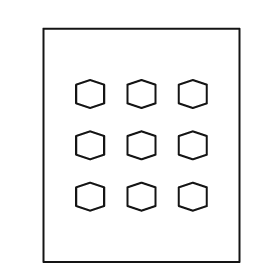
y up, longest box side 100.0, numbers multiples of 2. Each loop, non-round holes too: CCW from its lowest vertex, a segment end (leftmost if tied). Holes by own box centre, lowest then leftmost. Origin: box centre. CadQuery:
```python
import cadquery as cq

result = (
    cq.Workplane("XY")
    .moveTo(-42.0, -50.0)
    .lineTo(42.0, -50.0)
    .lineTo(42.0, 50.0)
    .lineTo(-42.0, 50.0)
    .close()
    .moveTo(-22.0, -28.0)
    .lineTo(-16.0, -26.0)
    .lineTo(-16.0, -18.0)
    .lineTo(-22.0, -16.0)
    .lineTo(-28.0, -18.0)
    .lineTo(-28.0, -26.0)
    .close()
    .moveTo(0.0, -28.0)
    .lineTo(6.0, -26.0)
    .lineTo(6.0, -18.0)
    .lineTo(0.0, -16.0)
    .lineTo(-6.0, -18.0)
    .lineTo(-6.0, -26.0)
    .close()
    .moveTo(22.0, -28.0)
    .lineTo(28.0, -26.0)
    .lineTo(28.0, -18.0)
    .lineTo(22.0, -16.0)
    .lineTo(16.0, -18.0)
    .lineTo(16.0, -26.0)
    .close()
    .moveTo(-22.0, -6.0)
    .lineTo(-16.0, -4.0)
    .lineTo(-16.0, 4.0)
    .lineTo(-22.0, 6.0)
    .lineTo(-28.0, 4.0)
    .lineTo(-28.0, -4.0)
    .close()
    .moveTo(0.0, -6.0)
    .lineTo(6.0, -4.0)
    .lineTo(6.0, 4.0)
    .lineTo(0.0, 6.0)
    .lineTo(-6.0, 4.0)
    .lineTo(-6.0, -4.0)
    .close()
    .moveTo(22.0, -6.0)
    .lineTo(28.0, -4.0)
    .lineTo(28.0, 4.0)
    .lineTo(22.0, 6.0)
    .lineTo(16.0, 4.0)
    .lineTo(16.0, -4.0)
    .close()
    .moveTo(-22.0, 16.0)
    .lineTo(-16.0, 18.0)
    .lineTo(-16.0, 26.0)
    .lineTo(-22.0, 28.0)
    .lineTo(-28.0, 26.0)
    .lineTo(-28.0, 18.0)
    .close()
    .moveTo(0.0, 16.0)
    .lineTo(6.0, 18.0)
    .lineTo(6.0, 26.0)
    .lineTo(0.0, 28.0)
    .lineTo(-6.0, 26.0)
    .lineTo(-6.0, 18.0)
    .close()
    .moveTo(22.0, 16.0)
    .lineTo(28.0, 18.0)
    .lineTo(28.0, 26.0)
    .lineTo(22.0, 28.0)
    .lineTo(16.0, 26.0)
    .lineTo(16.0, 18.0)
    .close()
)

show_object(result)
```